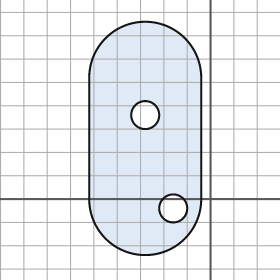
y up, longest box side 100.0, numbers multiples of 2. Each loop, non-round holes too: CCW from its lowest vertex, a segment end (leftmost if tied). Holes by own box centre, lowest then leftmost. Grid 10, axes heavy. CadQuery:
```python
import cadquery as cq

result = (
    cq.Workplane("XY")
    .moveTo(-52.0, 0.0)
    .threePointArc((-28.0, -24.0), (-4.0, 0.0))
    .lineTo(-4.0, 52.0)
    .threePointArc((-28.0, 76.0), (-52.0, 52.0))
    .close()
    .moveTo(-16.0, -4.0)
    .circle(6.0)
    .moveTo(-28.0, 36.0)
    .circle(6.0)
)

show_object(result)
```